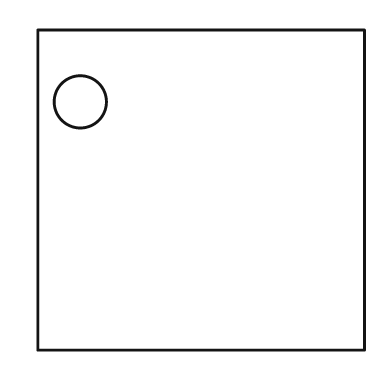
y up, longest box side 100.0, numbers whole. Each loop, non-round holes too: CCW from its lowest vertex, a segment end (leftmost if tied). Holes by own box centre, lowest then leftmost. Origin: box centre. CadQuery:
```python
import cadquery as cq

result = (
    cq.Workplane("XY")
    .moveTo(-50.0, -49.0)
    .lineTo(50.0, -49.0)
    .lineTo(50.0, 49.0)
    .lineTo(-50.0, 49.0)
    .close()
    .moveTo(-37.0, 27.0)
    .circle(8.0)
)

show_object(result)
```